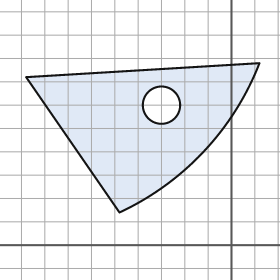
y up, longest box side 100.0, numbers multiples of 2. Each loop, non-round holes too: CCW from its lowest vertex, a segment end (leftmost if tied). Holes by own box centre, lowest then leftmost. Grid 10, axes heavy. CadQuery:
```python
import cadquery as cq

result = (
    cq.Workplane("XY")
    .moveTo(-48.0, 14.0)
    .threePointArc((-12.0, 40.0), (12.0, 78.0))
    .lineTo(-88.0, 72.0)
    .close()
    .moveTo(-30.0, 60.0)
    .circle(8.0)
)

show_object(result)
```